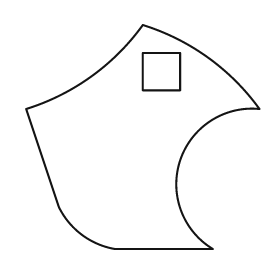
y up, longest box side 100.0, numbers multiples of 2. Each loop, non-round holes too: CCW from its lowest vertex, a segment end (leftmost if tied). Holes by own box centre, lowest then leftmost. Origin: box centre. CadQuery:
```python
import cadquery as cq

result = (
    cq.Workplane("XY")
    .moveTo(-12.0, -48.0)
    .lineTo(30.0, -48.0)
    .threePointArc((16.0, -10.0), (50.0, 12.0))
    .threePointArc((28.0, 34.0), (0.0, 48.0))
    .threePointArc((-22.0, 26.0), (-50.0, 12.0))
    .lineTo(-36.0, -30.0)
    .threePointArc((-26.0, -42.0), (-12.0, -48.0))
    .close()
    .moveTo(0.0, 20.0)
    .lineTo(16.0, 20.0)
    .lineTo(16.0, 36.0)
    .lineTo(0.0, 36.0)
    .close()
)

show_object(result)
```